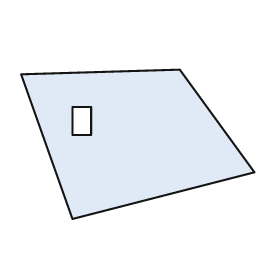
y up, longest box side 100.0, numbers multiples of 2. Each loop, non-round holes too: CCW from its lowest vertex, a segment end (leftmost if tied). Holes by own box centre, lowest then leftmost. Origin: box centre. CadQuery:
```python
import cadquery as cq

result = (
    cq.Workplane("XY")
    .moveTo(-28.0, -32.0)
    .lineTo(50.0, -12.0)
    .lineTo(18.0, 32.0)
    .lineTo(-50.0, 30.0)
    .close()
    .moveTo(-28.0, 4.0)
    .lineTo(-20.0, 4.0)
    .lineTo(-20.0, 16.0)
    .lineTo(-28.0, 16.0)
    .close()
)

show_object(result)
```